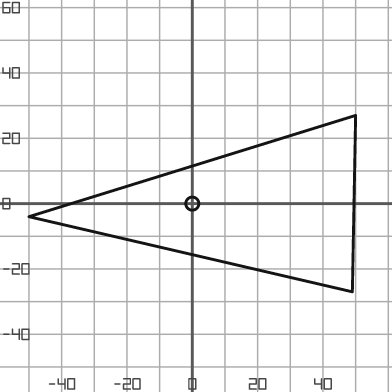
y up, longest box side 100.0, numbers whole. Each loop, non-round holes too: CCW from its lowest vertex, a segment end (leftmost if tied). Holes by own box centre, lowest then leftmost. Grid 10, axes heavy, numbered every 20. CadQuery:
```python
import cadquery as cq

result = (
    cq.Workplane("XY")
    .moveTo(49.0, -27.0)
    .lineTo(50.0, 27.0)
    .lineTo(-50.0, -4.0)
    .close()
    .moveTo(0.0, 0.0)
    .circle(2.0)
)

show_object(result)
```